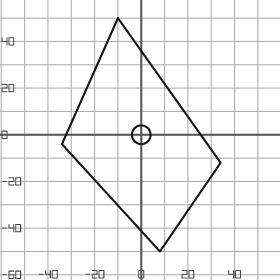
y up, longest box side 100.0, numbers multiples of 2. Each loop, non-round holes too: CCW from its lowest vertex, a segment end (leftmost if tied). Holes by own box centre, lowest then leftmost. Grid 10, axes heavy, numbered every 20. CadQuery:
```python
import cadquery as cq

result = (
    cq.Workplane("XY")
    .moveTo(8.0, -50.0)
    .lineTo(34.0, -12.0)
    .lineTo(-10.0, 50.0)
    .lineTo(-34.0, -4.0)
    .close()
    .moveTo(0.0, 0.0)
    .circle(4.0)
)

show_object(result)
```